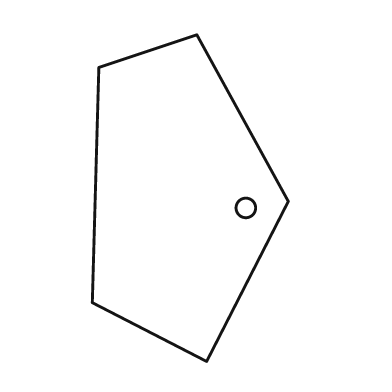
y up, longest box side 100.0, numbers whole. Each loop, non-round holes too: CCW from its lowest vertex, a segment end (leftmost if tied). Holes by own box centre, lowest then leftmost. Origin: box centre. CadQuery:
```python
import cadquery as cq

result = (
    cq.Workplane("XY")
    .moveTo(5.0, -50.0)
    .lineTo(30.0, -1.0)
    .lineTo(2.0, 50.0)
    .lineTo(-28.0, 40.0)
    .lineTo(-30.0, -32.0)
    .close()
    .moveTo(17.0, -3.0)
    .circle(3.0)
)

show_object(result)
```